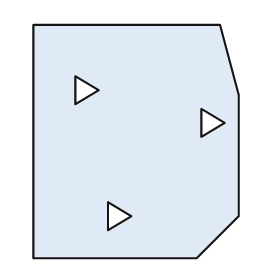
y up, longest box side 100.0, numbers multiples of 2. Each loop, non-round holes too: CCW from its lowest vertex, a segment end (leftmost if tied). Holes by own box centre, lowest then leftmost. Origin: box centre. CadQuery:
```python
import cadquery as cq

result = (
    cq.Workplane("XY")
    .moveTo(-44.0, -50.0)
    .lineTo(26.0, -50.0)
    .lineTo(44.0, -32.0)
    .lineTo(44.0, 20.0)
    .lineTo(36.0, 50.0)
    .lineTo(-44.0, 50.0)
    .close()
    .moveTo(-12.0, -38.0)
    .lineTo(-2.0, -32.0)
    .lineTo(-12.0, -26.0)
    .close()
    .moveTo(28.0, 2.0)
    .lineTo(38.0, 8.0)
    .lineTo(28.0, 14.0)
    .close()
    .moveTo(-26.0, 16.0)
    .lineTo(-16.0, 22.0)
    .lineTo(-26.0, 28.0)
    .close()
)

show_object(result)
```